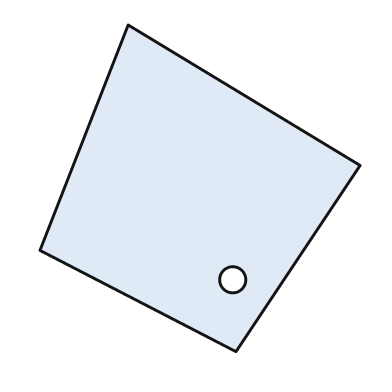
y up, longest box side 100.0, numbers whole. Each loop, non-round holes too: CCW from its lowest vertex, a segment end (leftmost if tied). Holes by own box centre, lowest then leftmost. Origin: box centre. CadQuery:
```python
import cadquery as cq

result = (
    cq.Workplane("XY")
    .moveTo(11.0, -50.0)
    .lineTo(49.0, 7.0)
    .lineTo(-22.0, 50.0)
    .lineTo(-49.0, -19.0)
    .close()
    .moveTo(10.0, -28.0)
    .circle(4.0)
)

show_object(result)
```